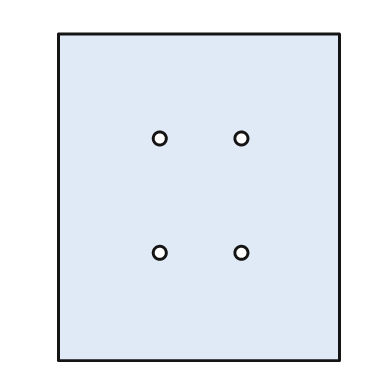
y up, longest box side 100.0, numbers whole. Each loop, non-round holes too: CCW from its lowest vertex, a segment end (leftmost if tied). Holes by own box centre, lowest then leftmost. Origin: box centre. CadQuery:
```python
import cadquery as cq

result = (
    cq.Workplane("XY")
    .moveTo(-43.0, -50.0)
    .lineTo(43.0, -50.0)
    .lineTo(43.0, 50.0)
    .lineTo(-43.0, 50.0)
    .close()
    .moveTo(-12.0, -17.0)
    .circle(2.0)
    .moveTo(13.0, -17.0)
    .circle(2.0)
    .moveTo(-12.0, 18.0)
    .circle(2.0)
    .moveTo(13.0, 18.0)
    .circle(2.0)
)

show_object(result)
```